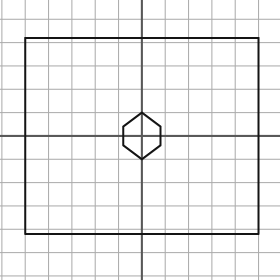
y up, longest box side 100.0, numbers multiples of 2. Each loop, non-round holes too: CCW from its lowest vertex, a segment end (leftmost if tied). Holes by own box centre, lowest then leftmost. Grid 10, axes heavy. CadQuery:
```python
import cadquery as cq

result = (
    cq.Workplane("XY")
    .moveTo(-50.0, -42.0)
    .lineTo(50.0, -42.0)
    .lineTo(50.0, 42.0)
    .lineTo(-50.0, 42.0)
    .close()
    .moveTo(0.0, -10.0)
    .lineTo(8.0, -4.0)
    .lineTo(8.0, 4.0)
    .lineTo(0.0, 10.0)
    .lineTo(-8.0, 4.0)
    .lineTo(-8.0, -4.0)
    .close()
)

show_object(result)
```